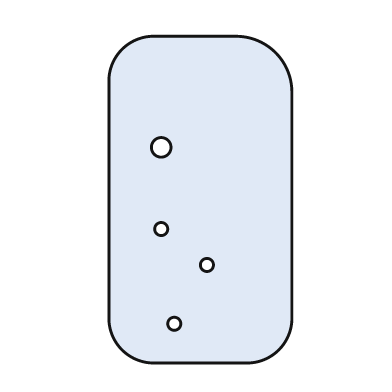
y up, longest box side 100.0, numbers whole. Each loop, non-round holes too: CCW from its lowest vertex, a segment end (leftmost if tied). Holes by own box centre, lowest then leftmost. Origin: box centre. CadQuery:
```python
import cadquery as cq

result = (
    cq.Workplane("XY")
    .moveTo(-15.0, -50.0)
    .lineTo(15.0, -50.0)
    .threePointArc((24.0, -46.0), (28.0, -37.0))
    .lineTo(28.0, 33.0)
    .threePointArc((23.0, 45.0), (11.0, 50.0))
    .lineTo(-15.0, 50.0)
    .threePointArc((-24.0, 46.0), (-28.0, 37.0))
    .lineTo(-28.0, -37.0)
    .threePointArc((-24.0, -46.0), (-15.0, -50.0))
    .close()
    .moveTo(-8.0, -38.0)
    .circle(2.0)
    .moveTo(2.0, -20.0)
    .circle(2.0)
    .moveTo(-12.0, -9.0)
    .circle(2.0)
    .moveTo(-12.0, 16.0)
    .circle(3.0)
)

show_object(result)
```